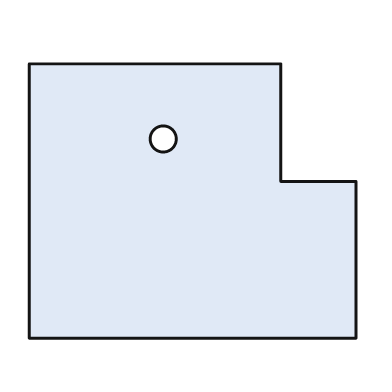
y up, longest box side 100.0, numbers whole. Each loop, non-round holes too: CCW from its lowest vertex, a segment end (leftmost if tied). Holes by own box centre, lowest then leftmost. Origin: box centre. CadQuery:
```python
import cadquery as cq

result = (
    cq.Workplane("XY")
    .moveTo(-50.0, -42.0)
    .lineTo(50.0, -42.0)
    .lineTo(50.0, 6.0)
    .lineTo(27.0, 6.0)
    .lineTo(27.0, 42.0)
    .lineTo(-50.0, 42.0)
    .close()
    .moveTo(-9.0, 19.0)
    .circle(4.0)
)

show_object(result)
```